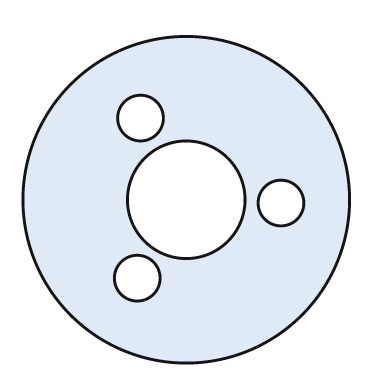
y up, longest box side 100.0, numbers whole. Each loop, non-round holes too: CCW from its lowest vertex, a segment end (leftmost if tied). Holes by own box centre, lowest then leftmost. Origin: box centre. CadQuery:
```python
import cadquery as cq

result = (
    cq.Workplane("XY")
    .moveTo(0.0, 0.0)
    .circle(50.0)
    .moveTo(-15.0, -24.0)
    .circle(7.0)
    .moveTo(29.0, -1.0)
    .circle(7.0)
    .moveTo(0.0, 0.0)
    .circle(18.0)
    .moveTo(-14.0, 25.0)
    .circle(7.0)
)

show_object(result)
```